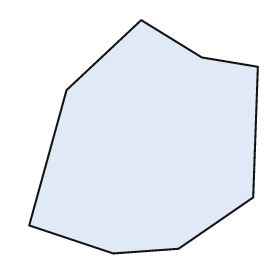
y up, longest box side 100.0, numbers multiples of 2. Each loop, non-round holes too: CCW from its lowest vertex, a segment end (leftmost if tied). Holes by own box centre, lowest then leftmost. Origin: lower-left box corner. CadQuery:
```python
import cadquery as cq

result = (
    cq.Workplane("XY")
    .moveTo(36.0, 0.0)
    .lineTo(64.0, 2.0)
    .lineTo(96.0, 24.0)
    .lineTo(98.0, 80.0)
    .lineTo(74.0, 84.0)
    .lineTo(48.0, 100.0)
    .lineTo(16.0, 70.0)
    .lineTo(0.0, 12.0)
    .close()
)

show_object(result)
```